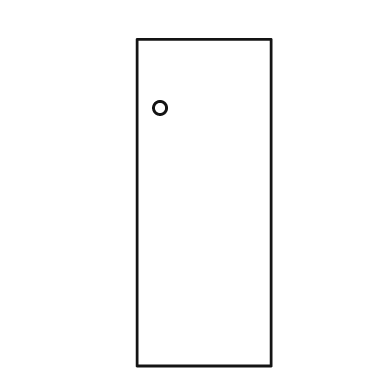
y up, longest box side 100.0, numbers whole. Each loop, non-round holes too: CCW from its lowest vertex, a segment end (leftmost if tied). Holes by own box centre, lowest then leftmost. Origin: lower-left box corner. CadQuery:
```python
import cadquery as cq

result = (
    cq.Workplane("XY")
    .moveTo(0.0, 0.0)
    .lineTo(41.0, 0.0)
    .lineTo(41.0, 100.0)
    .lineTo(0.0, 100.0)
    .close()
    .moveTo(7.0, 79.0)
    .circle(2.0)
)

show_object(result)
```